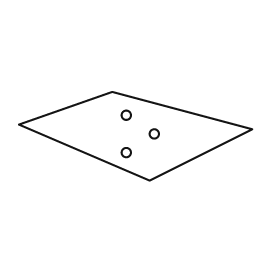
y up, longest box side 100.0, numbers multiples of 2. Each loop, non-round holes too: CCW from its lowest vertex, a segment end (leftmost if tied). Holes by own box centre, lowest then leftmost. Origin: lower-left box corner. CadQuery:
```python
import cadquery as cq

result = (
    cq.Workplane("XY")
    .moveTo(56.0, 0.0)
    .lineTo(100.0, 22.0)
    .lineTo(40.0, 38.0)
    .lineTo(0.0, 24.0)
    .close()
    .moveTo(46.0, 12.0)
    .circle(2.0)
    .moveTo(58.0, 20.0)
    .circle(2.0)
    .moveTo(46.0, 28.0)
    .circle(2.0)
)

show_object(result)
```